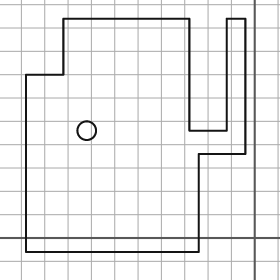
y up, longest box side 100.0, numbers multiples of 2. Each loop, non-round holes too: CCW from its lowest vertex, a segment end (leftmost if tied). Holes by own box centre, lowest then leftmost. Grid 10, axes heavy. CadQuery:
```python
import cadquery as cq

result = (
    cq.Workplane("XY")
    .moveTo(-98.0, -6.0)
    .lineTo(-24.0, -6.0)
    .lineTo(-24.0, 36.0)
    .lineTo(-4.0, 36.0)
    .lineTo(-4.0, 94.0)
    .lineTo(-12.0, 94.0)
    .lineTo(-12.0, 46.0)
    .lineTo(-28.0, 46.0)
    .lineTo(-28.0, 94.0)
    .lineTo(-82.0, 94.0)
    .lineTo(-82.0, 70.0)
    .lineTo(-98.0, 70.0)
    .close()
    .moveTo(-72.0, 46.0)
    .circle(4.0)
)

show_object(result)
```